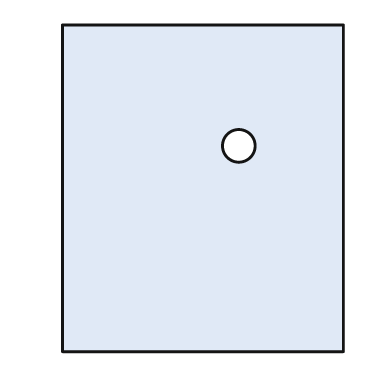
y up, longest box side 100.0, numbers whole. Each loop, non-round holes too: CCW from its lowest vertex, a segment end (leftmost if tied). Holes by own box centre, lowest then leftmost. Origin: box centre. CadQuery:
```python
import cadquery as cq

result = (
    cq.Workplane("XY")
    .moveTo(-43.0, -50.0)
    .lineTo(43.0, -50.0)
    .lineTo(43.0, 50.0)
    .lineTo(-43.0, 50.0)
    .close()
    .moveTo(11.0, 13.0)
    .circle(5.0)
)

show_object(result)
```